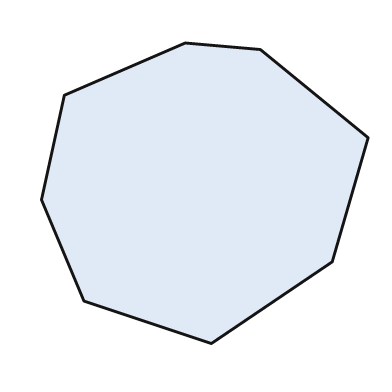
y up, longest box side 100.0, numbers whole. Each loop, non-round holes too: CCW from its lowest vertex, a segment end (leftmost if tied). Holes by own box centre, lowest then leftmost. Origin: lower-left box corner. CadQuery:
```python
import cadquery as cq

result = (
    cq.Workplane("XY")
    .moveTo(52.0, 0.0)
    .lineTo(89.0, 25.0)
    .lineTo(100.0, 63.0)
    .lineTo(67.0, 90.0)
    .lineTo(44.0, 92.0)
    .lineTo(7.0, 76.0)
    .lineTo(0.0, 44.0)
    .lineTo(13.0, 13.0)
    .close()
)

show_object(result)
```